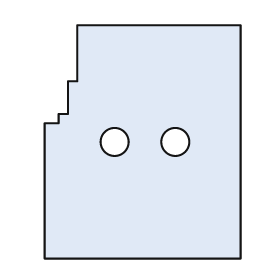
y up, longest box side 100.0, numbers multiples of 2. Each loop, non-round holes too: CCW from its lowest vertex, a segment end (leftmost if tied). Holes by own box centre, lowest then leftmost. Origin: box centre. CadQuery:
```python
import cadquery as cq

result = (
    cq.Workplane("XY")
    .moveTo(-42.0, -50.0)
    .lineTo(42.0, -50.0)
    .lineTo(42.0, 50.0)
    .lineTo(-28.0, 50.0)
    .lineTo(-28.0, 26.0)
    .lineTo(-32.0, 26.0)
    .lineTo(-32.0, 12.0)
    .lineTo(-36.0, 12.0)
    .lineTo(-36.0, 8.0)
    .lineTo(-42.0, 8.0)
    .close()
    .moveTo(-12.0, 0.0)
    .circle(6.0)
    .moveTo(14.0, 0.0)
    .circle(6.0)
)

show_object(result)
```